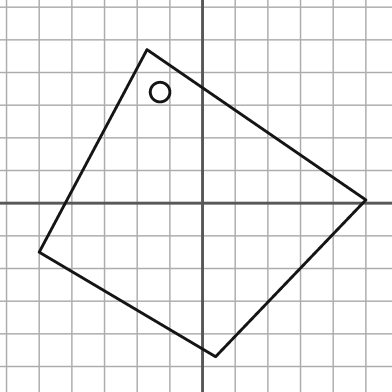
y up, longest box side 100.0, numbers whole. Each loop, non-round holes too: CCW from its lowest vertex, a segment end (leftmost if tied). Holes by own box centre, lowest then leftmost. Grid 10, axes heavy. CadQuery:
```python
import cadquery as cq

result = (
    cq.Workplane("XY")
    .moveTo(4.0, -47.0)
    .lineTo(50.0, 1.0)
    .lineTo(-17.0, 47.0)
    .lineTo(-50.0, -15.0)
    .close()
    .moveTo(-13.0, 34.0)
    .circle(3.0)
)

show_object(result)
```